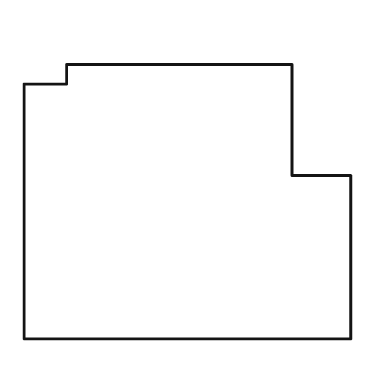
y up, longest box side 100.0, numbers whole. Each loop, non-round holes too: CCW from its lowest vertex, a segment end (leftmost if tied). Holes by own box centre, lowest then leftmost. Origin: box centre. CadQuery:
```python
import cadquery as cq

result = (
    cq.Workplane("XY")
    .moveTo(-50.0, -42.0)
    .lineTo(50.0, -42.0)
    .lineTo(50.0, 8.0)
    .lineTo(32.0, 8.0)
    .lineTo(32.0, 42.0)
    .lineTo(-37.0, 42.0)
    .lineTo(-37.0, 36.0)
    .lineTo(-50.0, 36.0)
    .close()
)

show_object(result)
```